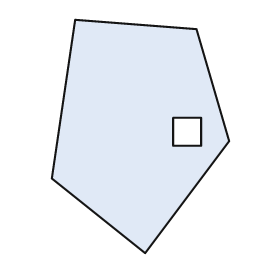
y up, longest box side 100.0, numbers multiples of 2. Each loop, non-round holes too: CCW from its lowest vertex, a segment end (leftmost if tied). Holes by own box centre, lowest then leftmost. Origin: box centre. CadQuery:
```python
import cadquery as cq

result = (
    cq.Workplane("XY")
    .moveTo(2.0, -50.0)
    .lineTo(38.0, -2.0)
    .lineTo(24.0, 46.0)
    .lineTo(-28.0, 50.0)
    .lineTo(-38.0, -18.0)
    .close()
    .moveTo(14.0, -4.0)
    .lineTo(26.0, -4.0)
    .lineTo(26.0, 8.0)
    .lineTo(14.0, 8.0)
    .close()
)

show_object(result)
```